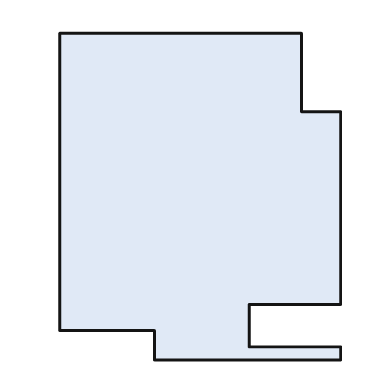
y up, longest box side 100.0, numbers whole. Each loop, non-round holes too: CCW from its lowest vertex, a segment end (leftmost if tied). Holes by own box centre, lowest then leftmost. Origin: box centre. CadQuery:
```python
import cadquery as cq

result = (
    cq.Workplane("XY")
    .moveTo(-14.0, -50.0)
    .lineTo(43.0, -50.0)
    .lineTo(43.0, -46.0)
    .lineTo(15.0, -46.0)
    .lineTo(15.0, -33.0)
    .lineTo(43.0, -33.0)
    .lineTo(43.0, 26.0)
    .lineTo(31.0, 26.0)
    .lineTo(31.0, 50.0)
    .lineTo(-43.0, 50.0)
    .lineTo(-43.0, -41.0)
    .lineTo(-14.0, -41.0)
    .close()
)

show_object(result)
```